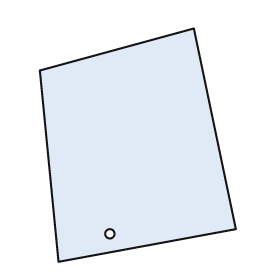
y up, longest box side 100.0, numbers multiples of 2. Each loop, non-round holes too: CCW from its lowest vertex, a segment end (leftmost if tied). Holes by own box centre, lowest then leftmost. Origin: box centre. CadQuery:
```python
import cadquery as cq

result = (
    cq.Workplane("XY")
    .moveTo(-34.0, -50.0)
    .lineTo(42.0, -36.0)
    .lineTo(24.0, 50.0)
    .lineTo(-42.0, 32.0)
    .close()
    .moveTo(-12.0, -38.0)
    .circle(2.0)
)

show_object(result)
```